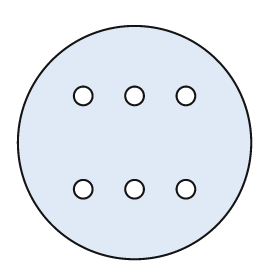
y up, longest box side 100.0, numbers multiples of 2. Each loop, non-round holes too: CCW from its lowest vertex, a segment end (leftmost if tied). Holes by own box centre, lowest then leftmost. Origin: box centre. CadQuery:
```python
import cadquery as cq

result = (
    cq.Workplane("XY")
    .moveTo(0.0, 0.0)
    .circle(50.0)
    .moveTo(-22.0, -20.0)
    .circle(4.0)
    .moveTo(0.0, -20.0)
    .circle(4.0)
    .moveTo(22.0, -20.0)
    .circle(4.0)
    .moveTo(-22.0, 20.0)
    .circle(4.0)
    .moveTo(0.0, 20.0)
    .circle(4.0)
    .moveTo(22.0, 20.0)
    .circle(4.0)
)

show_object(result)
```